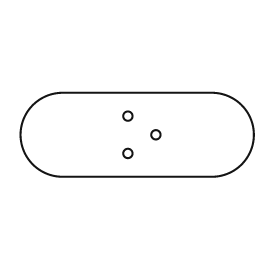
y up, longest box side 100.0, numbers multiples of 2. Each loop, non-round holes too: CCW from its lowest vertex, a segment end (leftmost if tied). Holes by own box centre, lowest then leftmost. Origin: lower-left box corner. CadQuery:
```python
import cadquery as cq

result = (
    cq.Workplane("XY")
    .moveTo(18.0, 0.0)
    .lineTo(82.0, 0.0)
    .threePointArc((100.0, 18.0), (82.0, 36.0))
    .lineTo(18.0, 36.0)
    .threePointArc((0.0, 18.0), (18.0, 0.0))
    .close()
    .moveTo(46.0, 10.0)
    .circle(2.0)
    .moveTo(58.0, 18.0)
    .circle(2.0)
    .moveTo(46.0, 26.0)
    .circle(2.0)
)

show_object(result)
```